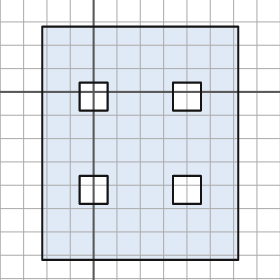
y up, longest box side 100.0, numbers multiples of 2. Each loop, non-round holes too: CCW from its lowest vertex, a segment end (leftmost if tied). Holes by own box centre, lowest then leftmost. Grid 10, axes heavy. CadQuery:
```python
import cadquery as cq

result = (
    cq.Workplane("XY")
    .moveTo(-22.0, -72.0)
    .lineTo(62.0, -72.0)
    .lineTo(62.0, 28.0)
    .lineTo(-22.0, 28.0)
    .close()
    .moveTo(-6.0, -48.0)
    .lineTo(6.0, -48.0)
    .lineTo(6.0, -36.0)
    .lineTo(-6.0, -36.0)
    .close()
    .moveTo(34.0, -48.0)
    .lineTo(46.0, -48.0)
    .lineTo(46.0, -36.0)
    .lineTo(34.0, -36.0)
    .close()
    .moveTo(-6.0, -8.0)
    .lineTo(6.0, -8.0)
    .lineTo(6.0, 4.0)
    .lineTo(-6.0, 4.0)
    .close()
    .moveTo(34.0, -8.0)
    .lineTo(46.0, -8.0)
    .lineTo(46.0, 4.0)
    .lineTo(34.0, 4.0)
    .close()
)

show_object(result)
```